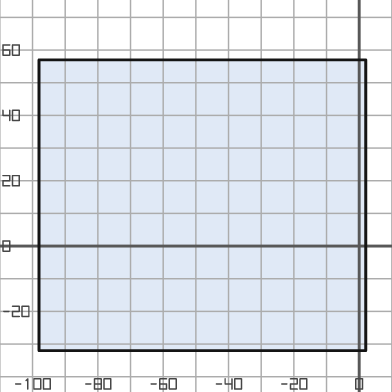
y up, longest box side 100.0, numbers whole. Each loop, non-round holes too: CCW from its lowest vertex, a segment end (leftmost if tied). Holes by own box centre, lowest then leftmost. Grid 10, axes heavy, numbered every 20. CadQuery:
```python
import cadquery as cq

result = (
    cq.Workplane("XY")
    .moveTo(-98.0, -32.0)
    .lineTo(2.0, -32.0)
    .lineTo(2.0, 57.0)
    .lineTo(-98.0, 57.0)
    .close()
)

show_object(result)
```